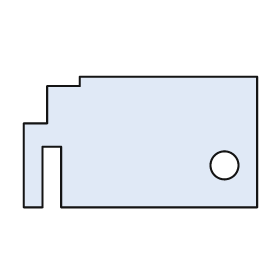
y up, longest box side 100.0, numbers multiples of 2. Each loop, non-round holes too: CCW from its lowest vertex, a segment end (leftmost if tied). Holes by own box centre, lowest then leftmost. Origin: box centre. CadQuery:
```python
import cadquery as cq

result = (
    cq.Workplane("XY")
    .moveTo(-50.0, -28.0)
    .lineTo(-42.0, -28.0)
    .lineTo(-42.0, -2.0)
    .lineTo(-34.0, -2.0)
    .lineTo(-34.0, -28.0)
    .lineTo(50.0, -28.0)
    .lineTo(50.0, 28.0)
    .lineTo(-26.0, 28.0)
    .lineTo(-26.0, 24.0)
    .lineTo(-40.0, 24.0)
    .lineTo(-40.0, 8.0)
    .lineTo(-50.0, 8.0)
    .close()
    .moveTo(36.0, -10.0)
    .circle(6.0)
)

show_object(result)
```